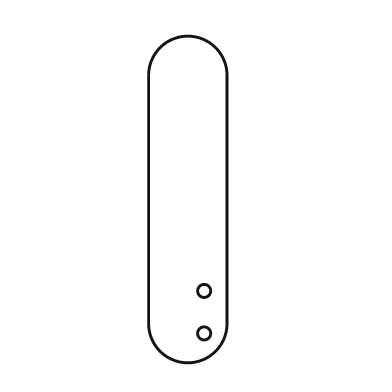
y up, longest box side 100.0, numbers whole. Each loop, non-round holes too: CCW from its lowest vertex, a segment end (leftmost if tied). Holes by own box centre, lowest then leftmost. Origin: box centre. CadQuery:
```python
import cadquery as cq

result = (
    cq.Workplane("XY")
    .moveTo(-12.0, -38.0)
    .threePointArc((0.0, -50.0), (12.0, -38.0))
    .lineTo(12.0, 38.0)
    .threePointArc((0.0, 50.0), (-12.0, 38.0))
    .close()
    .moveTo(5.0, -41.0)
    .circle(2.0)
    .moveTo(5.0, -28.0)
    .circle(2.0)
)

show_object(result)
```